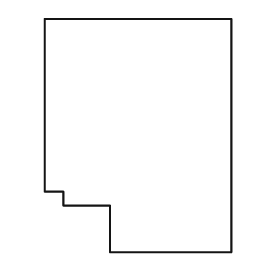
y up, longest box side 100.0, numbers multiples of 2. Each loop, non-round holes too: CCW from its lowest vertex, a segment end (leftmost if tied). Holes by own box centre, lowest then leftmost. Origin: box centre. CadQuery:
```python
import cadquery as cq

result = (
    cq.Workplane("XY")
    .moveTo(-12.0, -50.0)
    .lineTo(40.0, -50.0)
    .lineTo(40.0, 50.0)
    .lineTo(-40.0, 50.0)
    .lineTo(-40.0, -24.0)
    .lineTo(-32.0, -24.0)
    .lineTo(-32.0, -30.0)
    .lineTo(-12.0, -30.0)
    .close()
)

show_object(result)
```